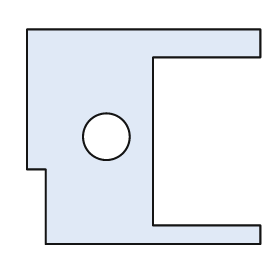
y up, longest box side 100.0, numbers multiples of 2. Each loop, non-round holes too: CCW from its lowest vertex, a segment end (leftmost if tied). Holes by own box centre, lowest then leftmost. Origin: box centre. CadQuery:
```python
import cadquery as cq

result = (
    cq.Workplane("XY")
    .moveTo(-42.0, -46.0)
    .lineTo(50.0, -46.0)
    .lineTo(50.0, -38.0)
    .lineTo(4.0, -38.0)
    .lineTo(4.0, 34.0)
    .lineTo(50.0, 34.0)
    .lineTo(50.0, 46.0)
    .lineTo(-50.0, 46.0)
    .lineTo(-50.0, -14.0)
    .lineTo(-42.0, -14.0)
    .close()
    .moveTo(-16.0, 0.0)
    .circle(10.0)
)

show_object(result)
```